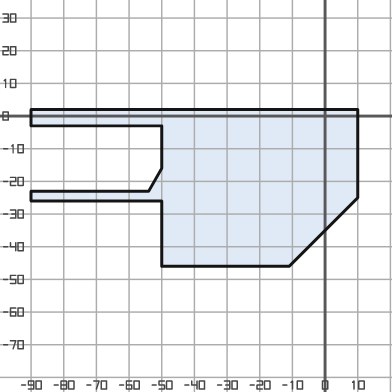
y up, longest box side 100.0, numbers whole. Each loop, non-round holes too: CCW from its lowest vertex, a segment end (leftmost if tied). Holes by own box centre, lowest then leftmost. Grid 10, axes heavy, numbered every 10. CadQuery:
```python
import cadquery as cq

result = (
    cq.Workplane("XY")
    .moveTo(-50.0, -46.0)
    .lineTo(-11.0, -46.0)
    .lineTo(10.0, -25.0)
    .lineTo(10.0, 2.0)
    .lineTo(-90.0, 2.0)
    .lineTo(-90.0, -3.0)
    .lineTo(-50.0, -3.0)
    .lineTo(-50.0, -16.0)
    .lineTo(-54.0, -23.0)
    .lineTo(-90.0, -23.0)
    .lineTo(-90.0, -26.0)
    .lineTo(-50.0, -26.0)
    .close()
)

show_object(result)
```